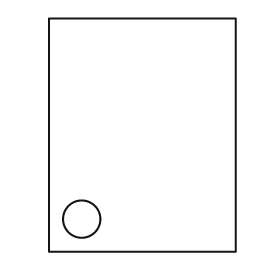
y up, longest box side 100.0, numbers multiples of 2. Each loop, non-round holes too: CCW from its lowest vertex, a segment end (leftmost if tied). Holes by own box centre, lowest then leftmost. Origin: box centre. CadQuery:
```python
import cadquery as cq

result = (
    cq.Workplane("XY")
    .moveTo(-40.0, -50.0)
    .lineTo(40.0, -50.0)
    .lineTo(40.0, 50.0)
    .lineTo(-40.0, 50.0)
    .close()
    .moveTo(-26.0, -36.0)
    .circle(8.0)
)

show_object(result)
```